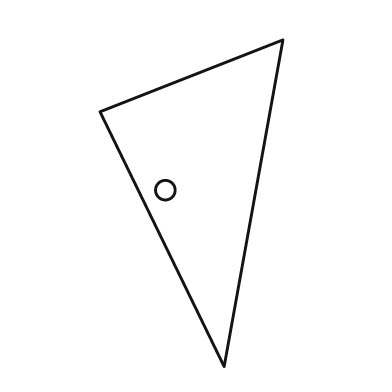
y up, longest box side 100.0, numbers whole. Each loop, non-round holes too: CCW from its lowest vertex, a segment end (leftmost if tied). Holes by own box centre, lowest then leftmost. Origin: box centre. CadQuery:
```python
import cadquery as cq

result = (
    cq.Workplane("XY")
    .moveTo(10.0, -50.0)
    .lineTo(28.0, 50.0)
    .lineTo(-28.0, 28.0)
    .close()
    .moveTo(-8.0, 4.0)
    .circle(3.0)
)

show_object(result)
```